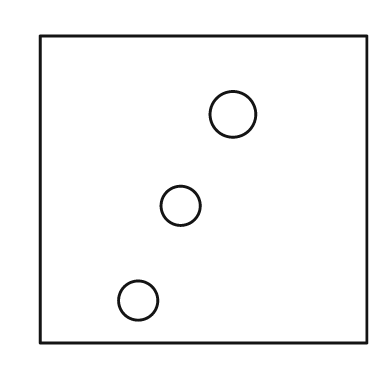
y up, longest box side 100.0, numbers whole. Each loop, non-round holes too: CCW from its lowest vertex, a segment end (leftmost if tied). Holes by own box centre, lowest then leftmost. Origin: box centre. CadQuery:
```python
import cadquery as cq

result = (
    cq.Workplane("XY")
    .moveTo(-50.0, -47.0)
    .lineTo(50.0, -47.0)
    .lineTo(50.0, 47.0)
    .lineTo(-50.0, 47.0)
    .close()
    .moveTo(-20.0, -34.0)
    .circle(6.0)
    .moveTo(-7.0, -5.0)
    .circle(6.0)
    .moveTo(9.0, 23.0)
    .circle(7.0)
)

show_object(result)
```